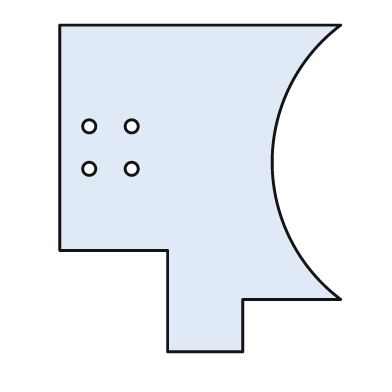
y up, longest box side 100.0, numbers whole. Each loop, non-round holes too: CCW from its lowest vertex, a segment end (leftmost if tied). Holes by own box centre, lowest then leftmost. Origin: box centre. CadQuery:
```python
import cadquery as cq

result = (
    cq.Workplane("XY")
    .moveTo(-10.0, -50.0)
    .lineTo(13.0, -50.0)
    .lineTo(13.0, -34.0)
    .lineTo(43.0, -34.0)
    .threePointArc((22.0, 8.0), (43.0, 50.0))
    .lineTo(-43.0, 50.0)
    .lineTo(-43.0, -19.0)
    .lineTo(-10.0, -19.0)
    .close()
    .moveTo(-34.0, 6.0)
    .circle(2.0)
    .moveTo(-21.0, 6.0)
    .circle(2.0)
    .moveTo(-34.0, 19.0)
    .circle(2.0)
    .moveTo(-21.0, 19.0)
    .circle(2.0)
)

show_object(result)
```